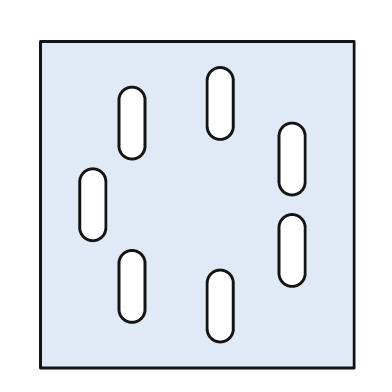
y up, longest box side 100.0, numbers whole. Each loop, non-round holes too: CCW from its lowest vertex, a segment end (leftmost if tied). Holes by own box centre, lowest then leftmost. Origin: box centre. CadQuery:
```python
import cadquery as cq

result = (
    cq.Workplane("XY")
    .moveTo(-48.0, -50.0)
    .lineTo(48.0, -50.0)
    .lineTo(48.0, 50.0)
    .lineTo(-48.0, 50.0)
    .close()
    .moveTo(3.0, -38.0)
    .threePointArc((7.0, -42.0), (11.0, -38.0))
    .lineTo(11.0, -24.0)
    .threePointArc((7.0, -20.0), (3.0, -24.0))
    .close()
    .moveTo(-24.0, -32.0)
    .threePointArc((-20.0, -36.0), (-16.0, -32.0))
    .lineTo(-16.0, -18.0)
    .threePointArc((-20.0, -14.0), (-24.0, -18.0))
    .close()
    .moveTo(25.0, -21.0)
    .threePointArc((29.0, -25.0), (33.0, -21.0))
    .lineTo(33.0, -7.0)
    .threePointArc((29.0, -3.0), (25.0, -7.0))
    .close()
    .moveTo(-36.0, -7.0)
    .threePointArc((-32.0, -11.0), (-28.0, -7.0))
    .lineTo(-28.0, 7.0)
    .threePointArc((-32.0, 11.0), (-36.0, 7.0))
    .close()
    .moveTo(25.0, 7.0)
    .threePointArc((29.0, 3.0), (33.0, 7.0))
    .lineTo(33.0, 21.0)
    .threePointArc((29.0, 25.0), (25.0, 21.0))
    .close()
    .moveTo(-24.0, 18.0)
    .threePointArc((-20.0, 14.0), (-16.0, 18.0))
    .lineTo(-16.0, 32.0)
    .threePointArc((-20.0, 36.0), (-24.0, 32.0))
    .close()
    .moveTo(3.0, 24.0)
    .threePointArc((7.0, 20.0), (11.0, 24.0))
    .lineTo(11.0, 38.0)
    .threePointArc((7.0, 42.0), (3.0, 38.0))
    .close()
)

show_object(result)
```